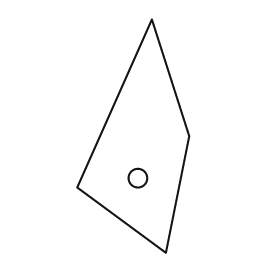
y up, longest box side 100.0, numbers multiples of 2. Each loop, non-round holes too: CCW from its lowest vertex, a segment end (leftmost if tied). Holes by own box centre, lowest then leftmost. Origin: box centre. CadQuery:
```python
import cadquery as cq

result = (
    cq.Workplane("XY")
    .moveTo(14.0, -50.0)
    .lineTo(24.0, 0.0)
    .lineTo(8.0, 50.0)
    .lineTo(-24.0, -22.0)
    .close()
    .moveTo(2.0, -18.0)
    .circle(4.0)
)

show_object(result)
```